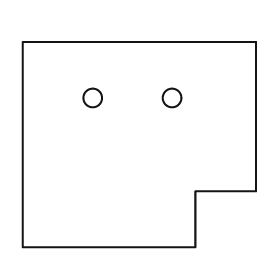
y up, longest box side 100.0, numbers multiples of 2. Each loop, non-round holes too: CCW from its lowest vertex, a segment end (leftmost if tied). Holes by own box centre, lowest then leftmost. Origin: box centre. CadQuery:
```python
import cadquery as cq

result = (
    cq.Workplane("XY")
    .moveTo(-50.0, -44.0)
    .lineTo(24.0, -44.0)
    .lineTo(24.0, -20.0)
    .lineTo(50.0, -20.0)
    .lineTo(50.0, 44.0)
    .lineTo(-50.0, 44.0)
    .close()
    .moveTo(-20.0, 20.0)
    .circle(4.0)
    .moveTo(14.0, 20.0)
    .circle(4.0)
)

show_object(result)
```